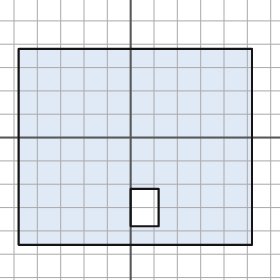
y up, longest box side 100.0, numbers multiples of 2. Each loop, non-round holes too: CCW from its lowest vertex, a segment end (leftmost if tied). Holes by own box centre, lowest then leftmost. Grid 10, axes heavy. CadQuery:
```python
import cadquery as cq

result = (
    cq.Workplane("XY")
    .moveTo(-48.0, -46.0)
    .lineTo(52.0, -46.0)
    .lineTo(52.0, 38.0)
    .lineTo(-48.0, 38.0)
    .close()
    .moveTo(0.0, -38.0)
    .lineTo(12.0, -38.0)
    .lineTo(12.0, -22.0)
    .lineTo(0.0, -22.0)
    .close()
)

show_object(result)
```